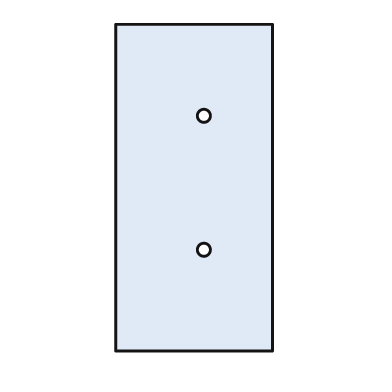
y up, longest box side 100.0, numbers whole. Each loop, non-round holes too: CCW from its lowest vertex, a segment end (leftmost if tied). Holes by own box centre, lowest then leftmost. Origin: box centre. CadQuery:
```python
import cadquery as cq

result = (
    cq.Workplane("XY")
    .moveTo(-24.0, -50.0)
    .lineTo(24.0, -50.0)
    .lineTo(24.0, 50.0)
    .lineTo(-24.0, 50.0)
    .close()
    .moveTo(3.0, -19.0)
    .circle(2.0)
    .moveTo(3.0, 22.0)
    .circle(2.0)
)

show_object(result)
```